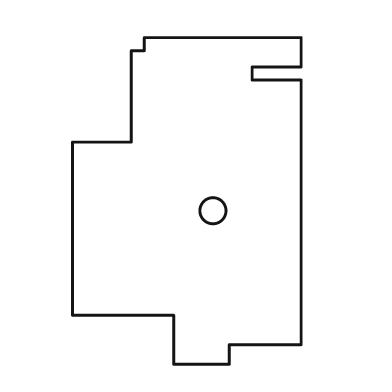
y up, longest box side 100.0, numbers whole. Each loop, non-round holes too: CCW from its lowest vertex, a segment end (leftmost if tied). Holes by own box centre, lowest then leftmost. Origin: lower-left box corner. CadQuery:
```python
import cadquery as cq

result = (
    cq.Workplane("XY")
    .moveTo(31.0, 0.0)
    .lineTo(48.0, 0.0)
    .lineTo(48.0, 6.0)
    .lineTo(70.0, 6.0)
    .lineTo(70.0, 87.0)
    .lineTo(55.0, 87.0)
    .lineTo(55.0, 91.0)
    .lineTo(70.0, 91.0)
    .lineTo(70.0, 100.0)
    .lineTo(22.0, 100.0)
    .lineTo(22.0, 96.0)
    .lineTo(18.0, 96.0)
    .lineTo(18.0, 68.0)
    .lineTo(0.0, 68.0)
    .lineTo(0.0, 15.0)
    .lineTo(31.0, 15.0)
    .close()
    .moveTo(43.0, 47.0)
    .circle(4.0)
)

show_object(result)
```